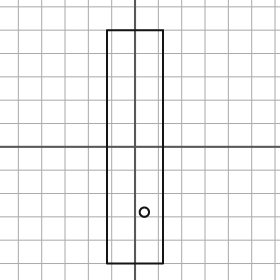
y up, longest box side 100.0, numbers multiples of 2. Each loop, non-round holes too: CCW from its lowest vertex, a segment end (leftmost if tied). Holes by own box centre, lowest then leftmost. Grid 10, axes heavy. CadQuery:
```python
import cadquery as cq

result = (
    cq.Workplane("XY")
    .moveTo(-12.0, -50.0)
    .lineTo(12.0, -50.0)
    .lineTo(12.0, 50.0)
    .lineTo(-12.0, 50.0)
    .close()
    .moveTo(4.0, -28.0)
    .circle(2.0)
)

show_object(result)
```